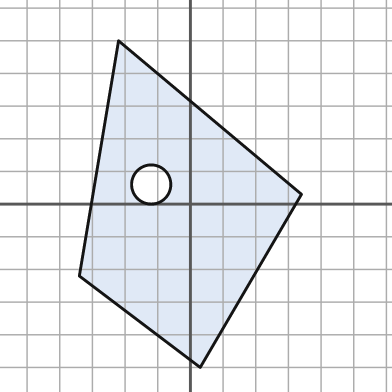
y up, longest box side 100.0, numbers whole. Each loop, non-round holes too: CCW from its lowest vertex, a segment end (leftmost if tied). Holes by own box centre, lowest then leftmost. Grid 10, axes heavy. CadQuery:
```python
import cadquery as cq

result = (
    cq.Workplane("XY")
    .moveTo(3.0, -50.0)
    .lineTo(34.0, 3.0)
    .lineTo(-22.0, 50.0)
    .lineTo(-34.0, -22.0)
    .close()
    .moveTo(-12.0, 6.0)
    .circle(6.0)
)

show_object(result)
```